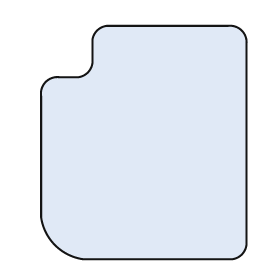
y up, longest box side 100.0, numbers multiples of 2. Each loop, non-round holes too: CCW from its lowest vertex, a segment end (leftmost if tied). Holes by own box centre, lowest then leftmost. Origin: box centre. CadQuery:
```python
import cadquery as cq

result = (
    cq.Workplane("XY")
    .moveTo(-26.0, -50.0)
    .lineTo(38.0, -50.0)
    .threePointArc((42.0, -48.0), (44.0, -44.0))
    .lineTo(44.0, 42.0)
    .threePointArc((42.0, 48.0), (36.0, 50.0))
    .lineTo(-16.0, 50.0)
    .threePointArc((-20.0, 48.0), (-22.0, 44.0))
    .lineTo(-22.0, 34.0)
    .threePointArc((-24.0, 30.0), (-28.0, 28.0))
    .lineTo(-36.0, 28.0)
    .threePointArc((-42.0, 26.0), (-44.0, 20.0))
    .lineTo(-44.0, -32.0)
    .threePointArc((-38.0, -44.0), (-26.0, -50.0))
    .close()
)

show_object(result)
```